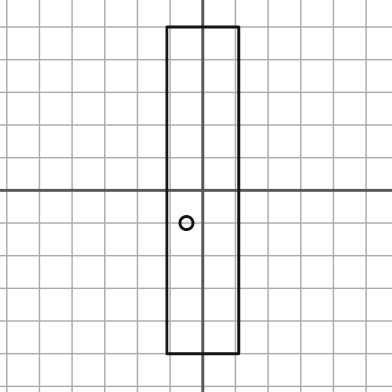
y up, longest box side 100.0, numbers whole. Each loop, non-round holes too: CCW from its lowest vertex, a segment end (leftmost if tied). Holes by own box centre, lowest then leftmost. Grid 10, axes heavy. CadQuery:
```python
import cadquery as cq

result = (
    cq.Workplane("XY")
    .moveTo(-11.0, -50.0)
    .lineTo(11.0, -50.0)
    .lineTo(11.0, 50.0)
    .lineTo(-11.0, 50.0)
    .close()
    .moveTo(-5.0, -10.0)
    .circle(2.0)
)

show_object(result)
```